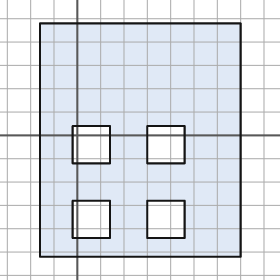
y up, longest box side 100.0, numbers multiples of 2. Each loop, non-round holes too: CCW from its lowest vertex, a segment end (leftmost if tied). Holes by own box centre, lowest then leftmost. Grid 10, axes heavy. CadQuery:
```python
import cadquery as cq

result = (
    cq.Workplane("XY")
    .moveTo(-16.0, -52.0)
    .lineTo(70.0, -52.0)
    .lineTo(70.0, 48.0)
    .lineTo(-16.0, 48.0)
    .close()
    .moveTo(-2.0, -44.0)
    .lineTo(14.0, -44.0)
    .lineTo(14.0, -28.0)
    .lineTo(-2.0, -28.0)
    .close()
    .moveTo(30.0, -44.0)
    .lineTo(46.0, -44.0)
    .lineTo(46.0, -28.0)
    .lineTo(30.0, -28.0)
    .close()
    .moveTo(-2.0, -12.0)
    .lineTo(14.0, -12.0)
    .lineTo(14.0, 4.0)
    .lineTo(-2.0, 4.0)
    .close()
    .moveTo(30.0, -12.0)
    .lineTo(46.0, -12.0)
    .lineTo(46.0, 4.0)
    .lineTo(30.0, 4.0)
    .close()
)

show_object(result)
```